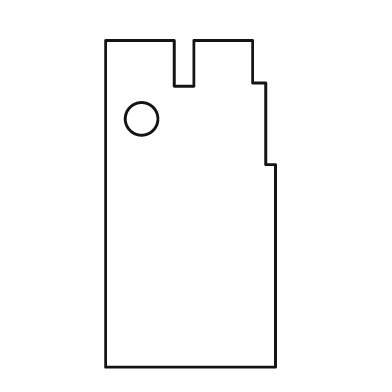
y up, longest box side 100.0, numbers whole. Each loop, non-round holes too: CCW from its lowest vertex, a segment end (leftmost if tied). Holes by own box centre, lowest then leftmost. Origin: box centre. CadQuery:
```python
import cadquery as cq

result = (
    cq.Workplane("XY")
    .moveTo(-26.0, -50.0)
    .lineTo(26.0, -50.0)
    .lineTo(26.0, 12.0)
    .lineTo(23.0, 12.0)
    .lineTo(23.0, 37.0)
    .lineTo(19.0, 37.0)
    .lineTo(19.0, 50.0)
    .lineTo(1.0, 50.0)
    .lineTo(1.0, 36.0)
    .lineTo(-5.0, 36.0)
    .lineTo(-5.0, 50.0)
    .lineTo(-26.0, 50.0)
    .close()
    .moveTo(-15.0, 26.0)
    .circle(5.0)
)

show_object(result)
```